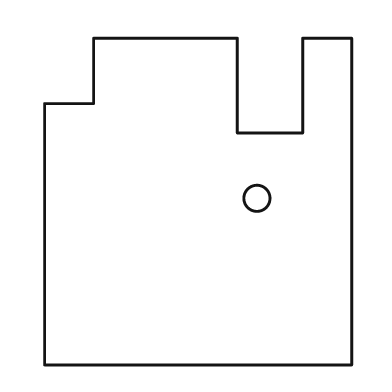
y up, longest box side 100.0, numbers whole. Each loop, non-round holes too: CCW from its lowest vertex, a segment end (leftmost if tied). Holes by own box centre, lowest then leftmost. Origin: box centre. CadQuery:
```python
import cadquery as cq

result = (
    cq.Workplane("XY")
    .moveTo(-47.0, -50.0)
    .lineTo(47.0, -50.0)
    .lineTo(47.0, 50.0)
    .lineTo(32.0, 50.0)
    .lineTo(32.0, 21.0)
    .lineTo(12.0, 21.0)
    .lineTo(12.0, 50.0)
    .lineTo(-32.0, 50.0)
    .lineTo(-32.0, 30.0)
    .lineTo(-47.0, 30.0)
    .close()
    .moveTo(18.0, 1.0)
    .circle(4.0)
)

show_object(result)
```